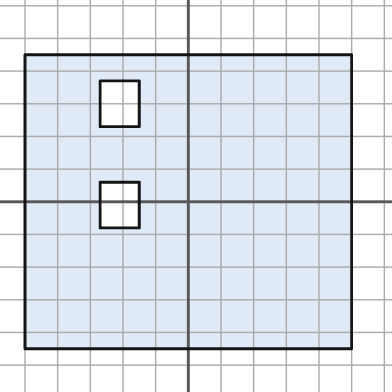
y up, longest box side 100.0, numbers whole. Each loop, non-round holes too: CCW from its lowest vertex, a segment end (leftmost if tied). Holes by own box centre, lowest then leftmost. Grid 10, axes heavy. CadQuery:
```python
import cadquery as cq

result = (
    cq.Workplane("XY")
    .moveTo(-50.0, -45.0)
    .lineTo(50.0, -45.0)
    .lineTo(50.0, 45.0)
    .lineTo(-50.0, 45.0)
    .close()
    .moveTo(-27.0, -8.0)
    .lineTo(-15.0, -8.0)
    .lineTo(-15.0, 6.0)
    .lineTo(-27.0, 6.0)
    .close()
    .moveTo(-27.0, 23.0)
    .lineTo(-15.0, 23.0)
    .lineTo(-15.0, 37.0)
    .lineTo(-27.0, 37.0)
    .close()
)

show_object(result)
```